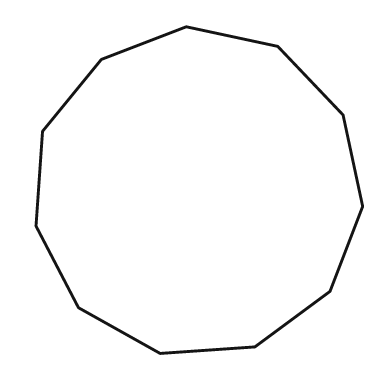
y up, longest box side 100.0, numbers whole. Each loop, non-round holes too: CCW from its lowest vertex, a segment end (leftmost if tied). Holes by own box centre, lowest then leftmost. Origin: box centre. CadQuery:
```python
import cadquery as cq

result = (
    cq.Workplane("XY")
    .moveTo(-12.0, -50.0)
    .lineTo(17.0, -48.0)
    .lineTo(40.0, -31.0)
    .lineTo(50.0, -5.0)
    .lineTo(44.0, 23.0)
    .lineTo(24.0, 44.0)
    .lineTo(-4.0, 50.0)
    .lineTo(-30.0, 40.0)
    .lineTo(-48.0, 18.0)
    .lineTo(-50.0, -11.0)
    .lineTo(-37.0, -36.0)
    .close()
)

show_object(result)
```